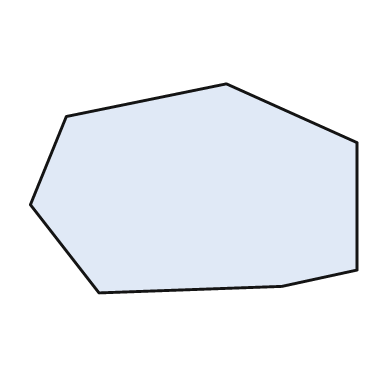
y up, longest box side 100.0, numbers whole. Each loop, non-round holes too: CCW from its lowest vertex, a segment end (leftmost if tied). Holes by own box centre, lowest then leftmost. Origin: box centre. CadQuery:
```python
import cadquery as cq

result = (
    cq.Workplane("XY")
    .moveTo(-29.0, -32.0)
    .lineTo(27.0, -30.0)
    .lineTo(50.0, -25.0)
    .lineTo(50.0, 14.0)
    .lineTo(10.0, 32.0)
    .lineTo(-39.0, 22.0)
    .lineTo(-50.0, -5.0)
    .close()
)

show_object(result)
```